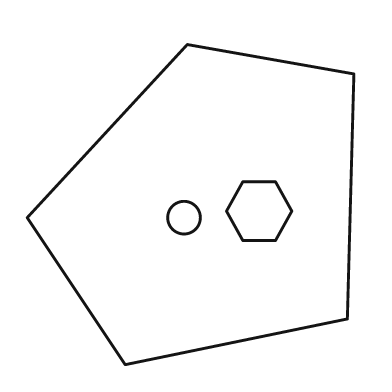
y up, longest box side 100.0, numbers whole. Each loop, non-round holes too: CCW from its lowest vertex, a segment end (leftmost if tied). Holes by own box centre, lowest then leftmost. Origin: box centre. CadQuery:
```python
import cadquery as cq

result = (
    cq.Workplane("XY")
    .moveTo(-20.0, -49.0)
    .lineTo(48.0, -35.0)
    .lineTo(50.0, 40.0)
    .lineTo(-1.0, 49.0)
    .lineTo(-50.0, -4.0)
    .close()
    .moveTo(-2.0, -4.0)
    .circle(5.0)
    .moveTo(16.0, -11.0)
    .lineTo(26.0, -11.0)
    .lineTo(31.0, -2.0)
    .lineTo(26.0, 7.0)
    .lineTo(16.0, 7.0)
    .lineTo(11.0, -2.0)
    .close()
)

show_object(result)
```